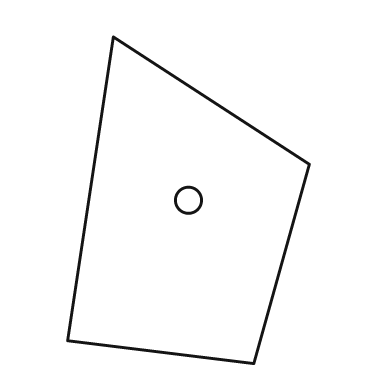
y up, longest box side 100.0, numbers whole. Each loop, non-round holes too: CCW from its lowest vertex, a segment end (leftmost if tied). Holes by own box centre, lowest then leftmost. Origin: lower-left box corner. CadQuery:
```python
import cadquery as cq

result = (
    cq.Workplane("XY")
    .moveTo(57.0, 0.0)
    .lineTo(74.0, 61.0)
    .lineTo(14.0, 100.0)
    .lineTo(0.0, 7.0)
    .close()
    .moveTo(37.0, 50.0)
    .circle(4.0)
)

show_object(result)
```